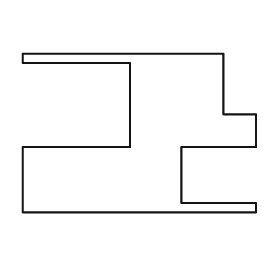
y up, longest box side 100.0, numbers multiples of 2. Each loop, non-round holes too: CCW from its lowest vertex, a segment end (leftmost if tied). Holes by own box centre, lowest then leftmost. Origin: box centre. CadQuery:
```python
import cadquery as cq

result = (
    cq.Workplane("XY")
    .moveTo(-50.0, -34.0)
    .lineTo(50.0, -34.0)
    .lineTo(50.0, -30.0)
    .lineTo(18.0, -30.0)
    .lineTo(18.0, -6.0)
    .lineTo(50.0, -6.0)
    .lineTo(50.0, 8.0)
    .lineTo(36.0, 8.0)
    .lineTo(36.0, 34.0)
    .lineTo(-50.0, 34.0)
    .lineTo(-50.0, 30.0)
    .lineTo(-4.0, 30.0)
    .lineTo(-4.0, -6.0)
    .lineTo(-50.0, -6.0)
    .close()
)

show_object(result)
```